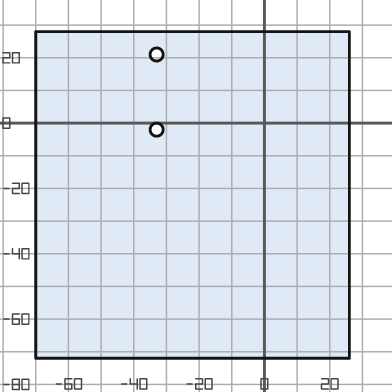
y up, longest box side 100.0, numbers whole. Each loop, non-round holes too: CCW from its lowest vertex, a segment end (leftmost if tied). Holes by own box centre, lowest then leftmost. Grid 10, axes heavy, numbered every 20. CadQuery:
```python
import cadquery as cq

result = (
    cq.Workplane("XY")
    .moveTo(-70.0, -72.0)
    .lineTo(26.0, -72.0)
    .lineTo(26.0, 28.0)
    .lineTo(-70.0, 28.0)
    .close()
    .moveTo(-33.0, -2.0)
    .circle(2.0)
    .moveTo(-33.0, 21.0)
    .circle(2.0)
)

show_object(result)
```